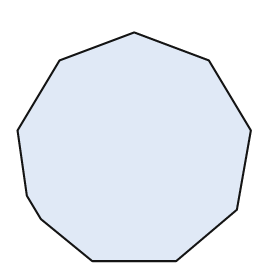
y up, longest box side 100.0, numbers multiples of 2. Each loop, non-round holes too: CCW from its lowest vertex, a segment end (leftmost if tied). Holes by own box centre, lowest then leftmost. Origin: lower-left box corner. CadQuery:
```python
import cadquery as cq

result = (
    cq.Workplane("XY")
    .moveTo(32.0, 0.0)
    .lineTo(68.0, 0.0)
    .lineTo(94.0, 22.0)
    .lineTo(100.0, 56.0)
    .lineTo(82.0, 86.0)
    .lineTo(50.0, 98.0)
    .lineTo(18.0, 86.0)
    .lineTo(0.0, 56.0)
    .lineTo(4.0, 28.0)
    .lineTo(10.0, 18.0)
    .close()
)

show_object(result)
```